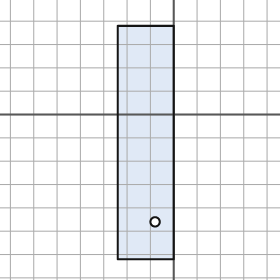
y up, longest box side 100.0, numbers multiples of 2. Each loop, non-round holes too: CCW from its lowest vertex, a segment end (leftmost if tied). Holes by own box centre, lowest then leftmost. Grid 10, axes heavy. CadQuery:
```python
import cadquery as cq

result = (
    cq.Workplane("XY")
    .moveTo(-24.0, -62.0)
    .lineTo(0.0, -62.0)
    .lineTo(0.0, 38.0)
    .lineTo(-24.0, 38.0)
    .close()
    .moveTo(-8.0, -46.0)
    .circle(2.0)
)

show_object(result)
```